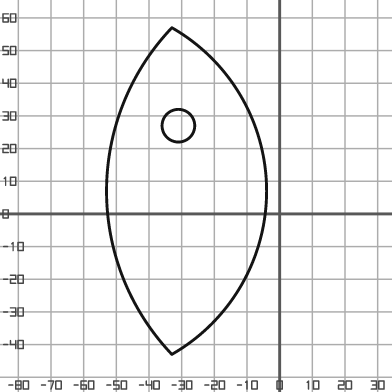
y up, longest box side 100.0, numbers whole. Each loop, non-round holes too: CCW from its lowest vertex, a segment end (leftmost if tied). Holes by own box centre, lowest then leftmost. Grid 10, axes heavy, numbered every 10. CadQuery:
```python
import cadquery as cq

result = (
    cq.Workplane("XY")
    .moveTo(-33.0, -43.0)
    .threePointArc((-4.0, 7.0), (-33.0, 57.0))
    .threePointArc((-53.0, 7.0), (-33.0, -43.0))
    .close()
    .moveTo(-31.0, 27.0)
    .circle(5.0)
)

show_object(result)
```